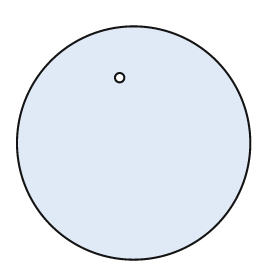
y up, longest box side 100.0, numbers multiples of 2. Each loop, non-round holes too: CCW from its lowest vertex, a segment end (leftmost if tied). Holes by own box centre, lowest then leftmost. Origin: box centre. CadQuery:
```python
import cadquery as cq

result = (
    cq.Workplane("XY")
    .moveTo(0.0, 0.0)
    .circle(50.0)
    .moveTo(-6.0, 28.0)
    .circle(2.0)
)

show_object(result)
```